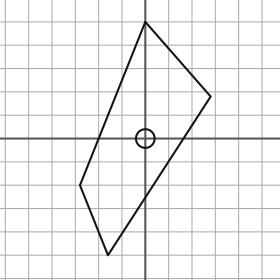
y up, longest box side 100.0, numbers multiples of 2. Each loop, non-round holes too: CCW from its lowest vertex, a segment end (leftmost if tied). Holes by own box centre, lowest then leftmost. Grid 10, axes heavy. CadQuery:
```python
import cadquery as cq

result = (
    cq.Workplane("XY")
    .moveTo(-16.0, -50.0)
    .lineTo(28.0, 18.0)
    .lineTo(0.0, 50.0)
    .lineTo(-28.0, -20.0)
    .close()
    .moveTo(0.0, 0.0)
    .circle(4.0)
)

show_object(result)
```